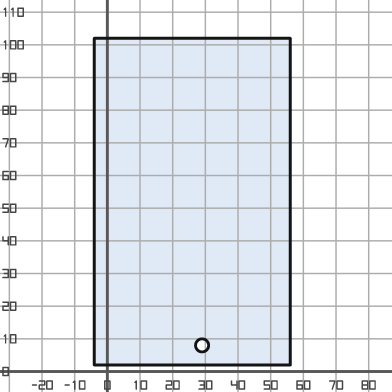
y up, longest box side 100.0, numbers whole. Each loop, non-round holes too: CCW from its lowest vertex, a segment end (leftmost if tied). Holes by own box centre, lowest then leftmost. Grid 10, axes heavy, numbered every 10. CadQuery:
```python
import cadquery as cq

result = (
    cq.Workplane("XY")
    .moveTo(-4.0, 2.0)
    .lineTo(56.0, 2.0)
    .lineTo(56.0, 102.0)
    .lineTo(-4.0, 102.0)
    .close()
    .moveTo(29.0, 8.0)
    .circle(2.0)
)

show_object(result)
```